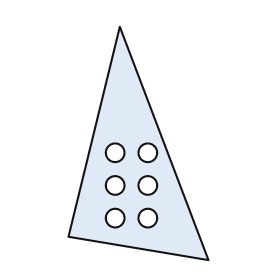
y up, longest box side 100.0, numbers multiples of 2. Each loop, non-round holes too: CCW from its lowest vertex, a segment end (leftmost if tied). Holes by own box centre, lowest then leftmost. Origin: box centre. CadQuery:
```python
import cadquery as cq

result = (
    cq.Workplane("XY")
    .moveTo(30.0, -50.0)
    .lineTo(-8.0, 50.0)
    .lineTo(-30.0, -40.0)
    .close()
    .moveTo(-10.0, -32.0)
    .circle(4.0)
    .moveTo(4.0, -32.0)
    .circle(4.0)
    .moveTo(-10.0, -18.0)
    .circle(4.0)
    .moveTo(4.0, -18.0)
    .circle(4.0)
    .moveTo(-10.0, -4.0)
    .circle(4.0)
    .moveTo(4.0, -4.0)
    .circle(4.0)
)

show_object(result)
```